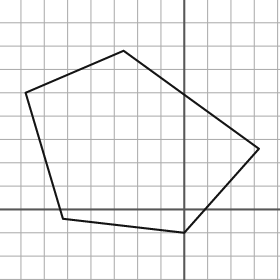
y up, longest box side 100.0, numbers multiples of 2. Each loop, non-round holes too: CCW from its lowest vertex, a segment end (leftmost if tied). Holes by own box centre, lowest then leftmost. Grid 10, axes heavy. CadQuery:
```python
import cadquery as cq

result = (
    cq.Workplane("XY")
    .moveTo(0.0, -10.0)
    .lineTo(32.0, 26.0)
    .lineTo(-26.0, 68.0)
    .lineTo(-68.0, 50.0)
    .lineTo(-52.0, -4.0)
    .close()
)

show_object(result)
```